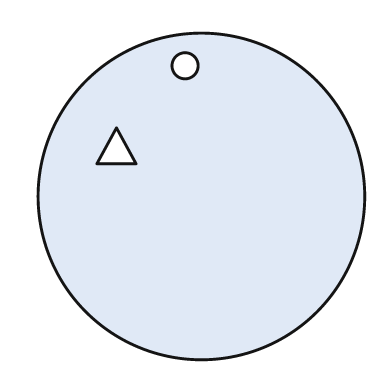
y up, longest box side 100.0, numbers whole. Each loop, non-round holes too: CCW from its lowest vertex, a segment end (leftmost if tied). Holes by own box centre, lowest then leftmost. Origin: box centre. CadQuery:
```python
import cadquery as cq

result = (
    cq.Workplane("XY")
    .moveTo(0.0, 0.0)
    .circle(50.0)
    .moveTo(-32.0, 10.0)
    .lineTo(-20.0, 10.0)
    .lineTo(-26.0, 21.0)
    .close()
    .moveTo(-5.0, 40.0)
    .circle(4.0)
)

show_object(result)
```